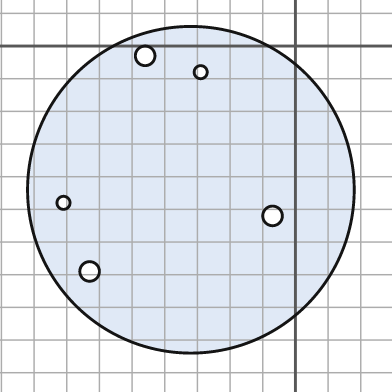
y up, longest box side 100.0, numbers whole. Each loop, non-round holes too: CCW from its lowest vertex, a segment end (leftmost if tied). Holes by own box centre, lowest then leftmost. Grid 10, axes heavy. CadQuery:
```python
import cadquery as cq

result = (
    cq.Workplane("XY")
    .moveTo(-32.0, -44.0)
    .circle(50.0)
    .moveTo(-63.0, -69.0)
    .circle(3.0)
    .moveTo(-7.0, -52.0)
    .circle(3.0)
    .moveTo(-71.0, -48.0)
    .circle(2.0)
    .moveTo(-29.0, -8.0)
    .circle(2.0)
    .moveTo(-46.0, -3.0)
    .circle(3.0)
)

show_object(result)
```